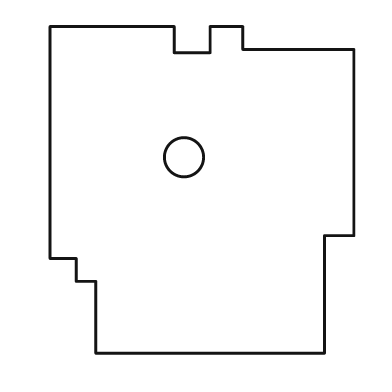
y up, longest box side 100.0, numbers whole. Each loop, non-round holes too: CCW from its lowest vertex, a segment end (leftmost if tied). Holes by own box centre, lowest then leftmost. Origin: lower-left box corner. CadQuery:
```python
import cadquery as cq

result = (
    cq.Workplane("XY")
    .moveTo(14.0, 0.0)
    .lineTo(84.0, 0.0)
    .lineTo(84.0, 36.0)
    .lineTo(93.0, 36.0)
    .lineTo(93.0, 93.0)
    .lineTo(59.0, 93.0)
    .lineTo(59.0, 100.0)
    .lineTo(49.0, 100.0)
    .lineTo(49.0, 92.0)
    .lineTo(38.0, 92.0)
    .lineTo(38.0, 100.0)
    .lineTo(0.0, 100.0)
    .lineTo(0.0, 29.0)
    .lineTo(8.0, 29.0)
    .lineTo(8.0, 22.0)
    .lineTo(14.0, 22.0)
    .close()
    .moveTo(41.0, 60.0)
    .circle(6.0)
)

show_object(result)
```